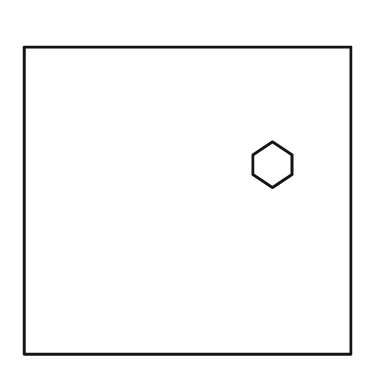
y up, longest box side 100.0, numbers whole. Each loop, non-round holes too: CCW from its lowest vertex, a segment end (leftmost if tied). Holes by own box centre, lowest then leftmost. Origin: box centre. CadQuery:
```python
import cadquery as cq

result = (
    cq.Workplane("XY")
    .moveTo(-50.0, -47.0)
    .lineTo(50.0, -47.0)
    .lineTo(50.0, 47.0)
    .lineTo(-50.0, 47.0)
    .close()
    .moveTo(26.0, 4.0)
    .lineTo(32.0, 8.0)
    .lineTo(32.0, 14.0)
    .lineTo(26.0, 18.0)
    .lineTo(20.0, 14.0)
    .lineTo(20.0, 8.0)
    .close()
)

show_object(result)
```